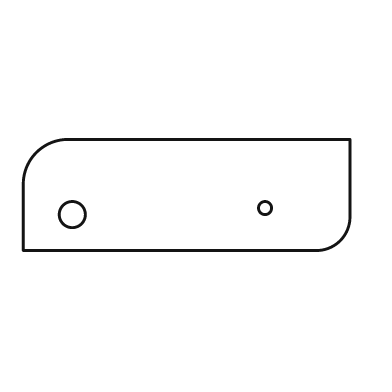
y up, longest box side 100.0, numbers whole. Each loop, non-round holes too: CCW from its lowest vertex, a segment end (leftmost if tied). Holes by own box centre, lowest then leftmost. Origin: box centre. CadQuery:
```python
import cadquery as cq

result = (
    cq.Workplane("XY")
    .moveTo(-50.0, -17.0)
    .lineTo(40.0, -17.0)
    .threePointArc((47.0, -14.0), (50.0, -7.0))
    .lineTo(50.0, 17.0)
    .lineTo(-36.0, 17.0)
    .threePointArc((-46.0, 13.0), (-50.0, 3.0))
    .close()
    .moveTo(-35.0, -6.0)
    .circle(4.0)
    .moveTo(24.0, -4.0)
    .circle(2.0)
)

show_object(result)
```